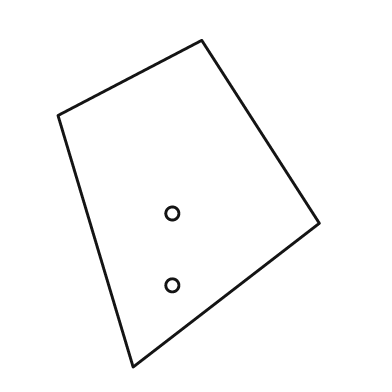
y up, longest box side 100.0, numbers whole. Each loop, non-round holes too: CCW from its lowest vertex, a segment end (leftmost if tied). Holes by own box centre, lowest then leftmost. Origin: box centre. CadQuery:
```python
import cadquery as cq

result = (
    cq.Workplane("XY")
    .moveTo(-17.0, -50.0)
    .lineTo(40.0, -6.0)
    .lineTo(4.0, 50.0)
    .lineTo(-40.0, 27.0)
    .close()
    .moveTo(-5.0, -25.0)
    .circle(2.0)
    .moveTo(-5.0, -3.0)
    .circle(2.0)
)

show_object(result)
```